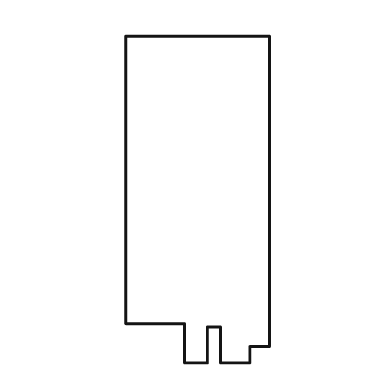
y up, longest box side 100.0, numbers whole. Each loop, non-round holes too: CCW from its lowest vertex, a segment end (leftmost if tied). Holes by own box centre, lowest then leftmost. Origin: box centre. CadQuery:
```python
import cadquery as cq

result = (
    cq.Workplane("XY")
    .moveTo(-4.0, -50.0)
    .lineTo(3.0, -50.0)
    .lineTo(3.0, -39.0)
    .lineTo(7.0, -39.0)
    .lineTo(7.0, -50.0)
    .lineTo(16.0, -50.0)
    .lineTo(16.0, -45.0)
    .lineTo(22.0, -45.0)
    .lineTo(22.0, 50.0)
    .lineTo(-22.0, 50.0)
    .lineTo(-22.0, -38.0)
    .lineTo(-4.0, -38.0)
    .close()
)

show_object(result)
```